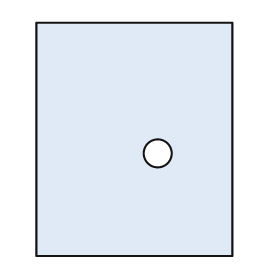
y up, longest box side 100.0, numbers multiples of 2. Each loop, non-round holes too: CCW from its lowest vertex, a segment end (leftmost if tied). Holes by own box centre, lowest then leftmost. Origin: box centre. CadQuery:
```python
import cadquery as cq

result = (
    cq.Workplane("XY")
    .moveTo(-42.0, -50.0)
    .lineTo(42.0, -50.0)
    .lineTo(42.0, 50.0)
    .lineTo(-42.0, 50.0)
    .close()
    .moveTo(10.0, -6.0)
    .circle(6.0)
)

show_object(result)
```